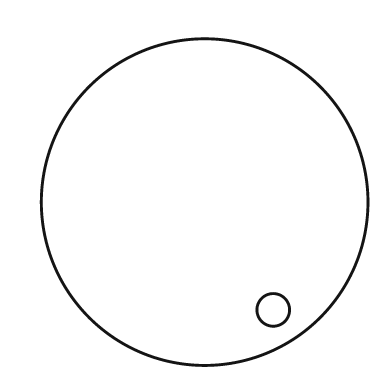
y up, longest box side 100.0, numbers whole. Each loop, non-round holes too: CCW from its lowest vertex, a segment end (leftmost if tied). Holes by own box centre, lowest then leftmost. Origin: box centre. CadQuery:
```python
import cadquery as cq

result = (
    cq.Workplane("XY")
    .moveTo(0.0, 0.0)
    .circle(50.0)
    .moveTo(21.0, -33.0)
    .circle(5.0)
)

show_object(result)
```